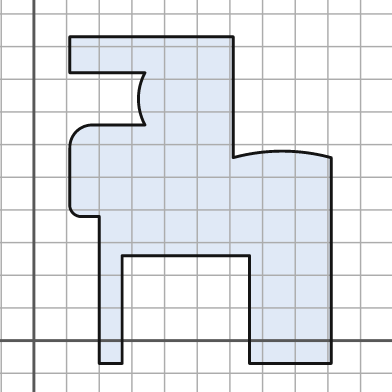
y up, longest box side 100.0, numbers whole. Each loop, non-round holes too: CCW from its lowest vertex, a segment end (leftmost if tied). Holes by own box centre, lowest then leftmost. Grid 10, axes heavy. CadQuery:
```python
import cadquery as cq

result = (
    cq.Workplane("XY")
    .moveTo(20.0, -7.0)
    .lineTo(27.0, -7.0)
    .lineTo(27.0, 26.0)
    .lineTo(66.0, 26.0)
    .lineTo(66.0, -7.0)
    .lineTo(91.0, -7.0)
    .lineTo(91.0, 56.0)
    .threePointArc((76.0, 58.0), (61.0, 56.0))
    .lineTo(61.0, 93.0)
    .lineTo(11.0, 93.0)
    .lineTo(11.0, 82.0)
    .lineTo(34.0, 82.0)
    .threePointArc((32.0, 74.0), (34.0, 66.0))
    .lineTo(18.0, 66.0)
    .threePointArc((13.0, 64.0), (11.0, 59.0))
    .lineTo(11.0, 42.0)
    .threePointArc((12.0, 39.0), (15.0, 38.0))
    .lineTo(20.0, 38.0)
    .close()
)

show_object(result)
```